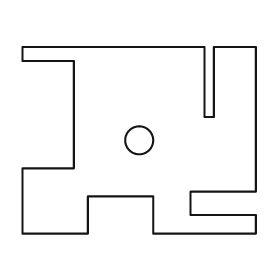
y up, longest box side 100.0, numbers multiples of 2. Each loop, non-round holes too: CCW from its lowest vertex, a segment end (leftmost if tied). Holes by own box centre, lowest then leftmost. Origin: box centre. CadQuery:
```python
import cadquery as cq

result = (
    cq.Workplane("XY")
    .moveTo(-50.0, -40.0)
    .lineTo(-22.0, -40.0)
    .lineTo(-22.0, -24.0)
    .lineTo(6.0, -24.0)
    .lineTo(6.0, -40.0)
    .lineTo(50.0, -40.0)
    .lineTo(50.0, -32.0)
    .lineTo(22.0, -32.0)
    .lineTo(22.0, -22.0)
    .lineTo(50.0, -22.0)
    .lineTo(50.0, 40.0)
    .lineTo(32.0, 40.0)
    .lineTo(32.0, 10.0)
    .lineTo(28.0, 10.0)
    .lineTo(28.0, 40.0)
    .lineTo(-50.0, 40.0)
    .lineTo(-50.0, 34.0)
    .lineTo(-28.0, 34.0)
    .lineTo(-28.0, -12.0)
    .lineTo(-50.0, -12.0)
    .close()
    .moveTo(0.0, 0.0)
    .circle(6.0)
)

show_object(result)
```